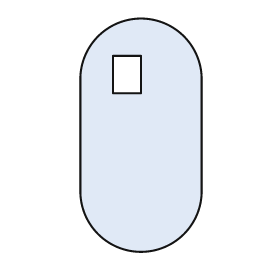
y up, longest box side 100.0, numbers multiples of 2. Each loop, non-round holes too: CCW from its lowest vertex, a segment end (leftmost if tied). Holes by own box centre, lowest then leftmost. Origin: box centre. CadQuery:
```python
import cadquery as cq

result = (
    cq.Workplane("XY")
    .moveTo(-26.0, -24.0)
    .threePointArc((0.0, -50.0), (26.0, -24.0))
    .lineTo(26.0, 24.0)
    .threePointArc((0.0, 50.0), (-26.0, 24.0))
    .close()
    .moveTo(-12.0, 18.0)
    .lineTo(0.0, 18.0)
    .lineTo(0.0, 34.0)
    .lineTo(-12.0, 34.0)
    .close()
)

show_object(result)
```